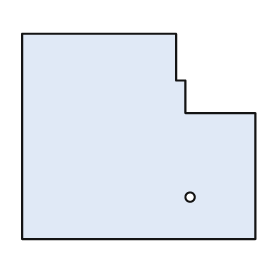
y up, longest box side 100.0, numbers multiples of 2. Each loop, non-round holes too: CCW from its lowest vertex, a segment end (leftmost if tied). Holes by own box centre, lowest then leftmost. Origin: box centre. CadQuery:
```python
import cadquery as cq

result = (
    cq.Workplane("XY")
    .moveTo(-50.0, -44.0)
    .lineTo(50.0, -44.0)
    .lineTo(50.0, 10.0)
    .lineTo(20.0, 10.0)
    .lineTo(20.0, 24.0)
    .lineTo(16.0, 24.0)
    .lineTo(16.0, 44.0)
    .lineTo(-50.0, 44.0)
    .close()
    .moveTo(22.0, -26.0)
    .circle(2.0)
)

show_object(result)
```